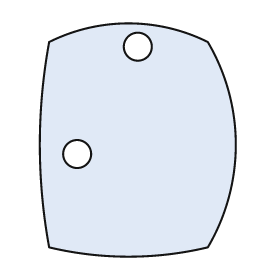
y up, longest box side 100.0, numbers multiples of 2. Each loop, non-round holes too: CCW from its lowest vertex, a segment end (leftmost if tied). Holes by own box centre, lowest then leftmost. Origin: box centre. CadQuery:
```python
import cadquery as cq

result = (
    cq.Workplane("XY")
    .moveTo(-38.0, -46.0)
    .threePointArc((-4.0, -50.0), (30.0, -46.0))
    .threePointArc((42.0, -2.0), (30.0, 42.0))
    .threePointArc((-4.0, 50.0), (-38.0, 42.0))
    .threePointArc((-42.0, -2.0), (-38.0, -46.0))
    .close()
    .moveTo(-26.0, -6.0)
    .circle(6.0)
    .moveTo(0.0, 40.0)
    .circle(6.0)
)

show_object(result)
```